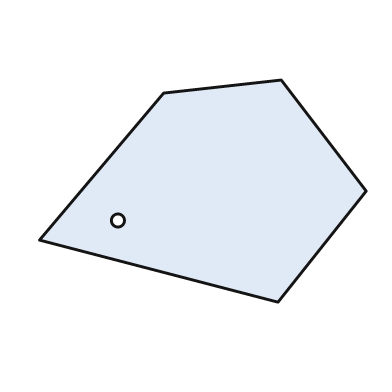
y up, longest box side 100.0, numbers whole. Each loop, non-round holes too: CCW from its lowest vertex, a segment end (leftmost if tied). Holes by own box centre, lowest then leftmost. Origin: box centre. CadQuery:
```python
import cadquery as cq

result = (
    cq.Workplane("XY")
    .moveTo(23.0, -34.0)
    .lineTo(50.0, 0.0)
    .lineTo(24.0, 34.0)
    .lineTo(-12.0, 30.0)
    .lineTo(-50.0, -15.0)
    .close()
    .moveTo(-26.0, -9.0)
    .circle(2.0)
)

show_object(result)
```